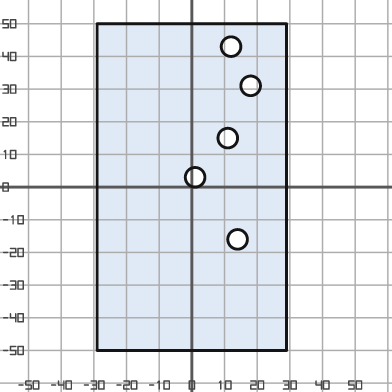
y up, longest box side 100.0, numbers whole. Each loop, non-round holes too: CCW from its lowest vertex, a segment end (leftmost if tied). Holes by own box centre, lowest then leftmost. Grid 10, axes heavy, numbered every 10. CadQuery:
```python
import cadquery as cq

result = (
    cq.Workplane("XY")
    .moveTo(-29.0, -50.0)
    .lineTo(29.0, -50.0)
    .lineTo(29.0, 50.0)
    .lineTo(-29.0, 50.0)
    .close()
    .moveTo(14.0, -16.0)
    .circle(3.0)
    .moveTo(1.0, 3.0)
    .circle(3.0)
    .moveTo(11.0, 15.0)
    .circle(3.0)
    .moveTo(18.0, 31.0)
    .circle(3.0)
    .moveTo(12.0, 43.0)
    .circle(3.0)
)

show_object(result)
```